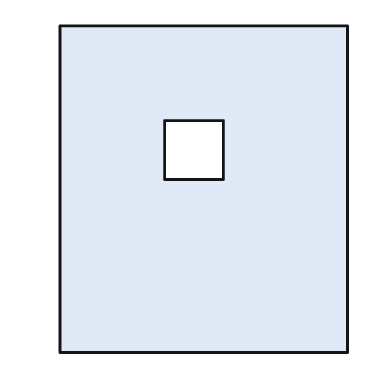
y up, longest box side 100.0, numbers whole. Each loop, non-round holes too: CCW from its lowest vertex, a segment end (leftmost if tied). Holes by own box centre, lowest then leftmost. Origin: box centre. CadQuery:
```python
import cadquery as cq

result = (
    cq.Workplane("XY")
    .moveTo(-44.0, -50.0)
    .lineTo(44.0, -50.0)
    .lineTo(44.0, 50.0)
    .lineTo(-44.0, 50.0)
    .close()
    .moveTo(-12.0, 3.0)
    .lineTo(6.0, 3.0)
    .lineTo(6.0, 21.0)
    .lineTo(-12.0, 21.0)
    .close()
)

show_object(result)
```